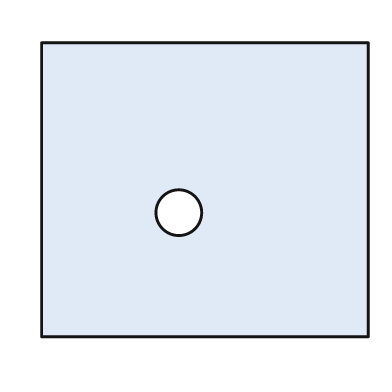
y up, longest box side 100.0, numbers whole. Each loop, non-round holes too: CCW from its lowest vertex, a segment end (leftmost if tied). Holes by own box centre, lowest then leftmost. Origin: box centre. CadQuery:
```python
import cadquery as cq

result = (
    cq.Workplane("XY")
    .moveTo(-50.0, -45.0)
    .lineTo(50.0, -45.0)
    .lineTo(50.0, 45.0)
    .lineTo(-50.0, 45.0)
    .close()
    .moveTo(-8.0, -7.0)
    .circle(7.0)
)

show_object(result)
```